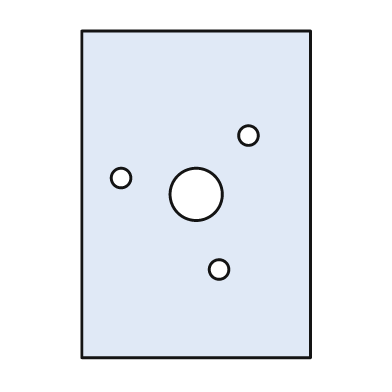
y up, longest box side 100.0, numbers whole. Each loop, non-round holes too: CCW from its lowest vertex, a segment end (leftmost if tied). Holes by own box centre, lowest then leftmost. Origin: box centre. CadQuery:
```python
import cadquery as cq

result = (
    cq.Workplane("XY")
    .moveTo(-35.0, -50.0)
    .lineTo(35.0, -50.0)
    .lineTo(35.0, 50.0)
    .lineTo(-35.0, 50.0)
    .close()
    .moveTo(7.0, -23.0)
    .circle(3.0)
    .moveTo(0.0, 0.0)
    .circle(8.0)
    .moveTo(-23.0, 5.0)
    .circle(3.0)
    .moveTo(16.0, 18.0)
    .circle(3.0)
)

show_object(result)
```